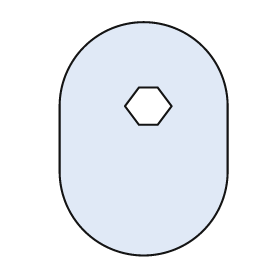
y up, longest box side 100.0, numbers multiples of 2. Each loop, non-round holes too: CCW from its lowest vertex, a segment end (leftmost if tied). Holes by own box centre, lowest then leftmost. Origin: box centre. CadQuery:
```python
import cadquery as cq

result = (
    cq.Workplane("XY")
    .moveTo(-36.0, -14.0)
    .threePointArc((0.0, -50.0), (36.0, -14.0))
    .lineTo(36.0, 14.0)
    .threePointArc((0.0, 50.0), (-36.0, 14.0))
    .close()
    .moveTo(-2.0, 6.0)
    .lineTo(6.0, 6.0)
    .lineTo(12.0, 14.0)
    .lineTo(6.0, 22.0)
    .lineTo(-2.0, 22.0)
    .lineTo(-8.0, 14.0)
    .close()
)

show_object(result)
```